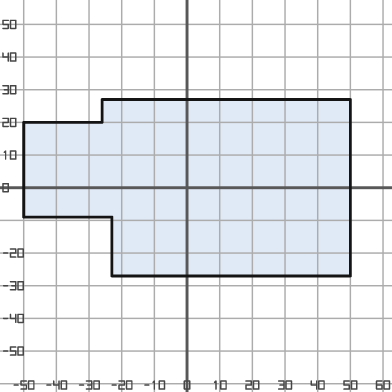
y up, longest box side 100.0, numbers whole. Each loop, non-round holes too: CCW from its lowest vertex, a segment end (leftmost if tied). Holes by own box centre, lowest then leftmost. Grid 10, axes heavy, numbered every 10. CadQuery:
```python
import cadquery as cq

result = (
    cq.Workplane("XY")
    .moveTo(-23.0, -27.0)
    .lineTo(50.0, -27.0)
    .lineTo(50.0, 27.0)
    .lineTo(-26.0, 27.0)
    .lineTo(-26.0, 20.0)
    .lineTo(-50.0, 20.0)
    .lineTo(-50.0, -9.0)
    .lineTo(-23.0, -9.0)
    .close()
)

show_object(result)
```